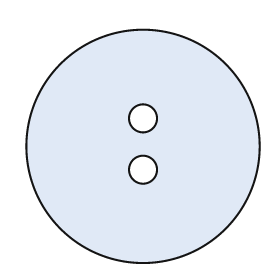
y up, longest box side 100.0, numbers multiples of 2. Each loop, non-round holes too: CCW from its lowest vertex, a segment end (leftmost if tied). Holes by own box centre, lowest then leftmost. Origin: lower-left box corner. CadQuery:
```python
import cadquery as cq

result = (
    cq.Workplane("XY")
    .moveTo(50.0, 50.0)
    .circle(50.0)
    .moveTo(50.0, 40.0)
    .circle(6.0)
    .moveTo(50.0, 62.0)
    .circle(6.0)
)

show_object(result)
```